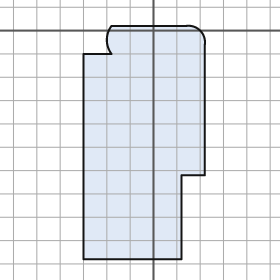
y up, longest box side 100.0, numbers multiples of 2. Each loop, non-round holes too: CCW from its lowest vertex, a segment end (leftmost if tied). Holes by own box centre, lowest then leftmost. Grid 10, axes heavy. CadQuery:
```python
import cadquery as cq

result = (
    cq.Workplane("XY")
    .moveTo(-30.0, -98.0)
    .lineTo(12.0, -98.0)
    .lineTo(12.0, -62.0)
    .lineTo(22.0, -62.0)
    .lineTo(22.0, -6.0)
    .threePointArc((20.0, 0.0), (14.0, 2.0))
    .lineTo(-18.0, 2.0)
    .threePointArc((-20.0, -4.0), (-18.0, -10.0))
    .lineTo(-30.0, -10.0)
    .close()
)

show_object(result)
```